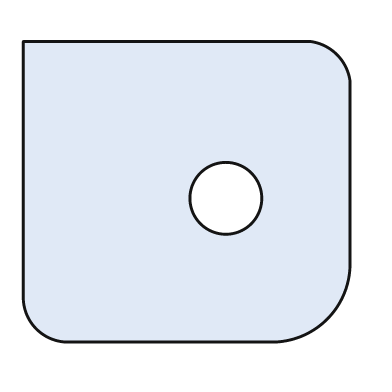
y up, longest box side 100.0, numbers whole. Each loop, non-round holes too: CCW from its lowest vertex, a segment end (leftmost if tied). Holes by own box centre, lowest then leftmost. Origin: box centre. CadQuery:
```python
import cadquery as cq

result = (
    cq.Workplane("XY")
    .moveTo(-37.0, -46.0)
    .lineTo(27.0, -46.0)
    .threePointArc((43.0, -39.0), (50.0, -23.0))
    .lineTo(50.0, 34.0)
    .threePointArc((46.0, 42.0), (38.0, 46.0))
    .lineTo(-50.0, 46.0)
    .lineTo(-50.0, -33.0)
    .threePointArc((-46.0, -42.0), (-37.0, -46.0))
    .close()
    .moveTo(12.0, -2.0)
    .circle(11.0)
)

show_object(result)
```